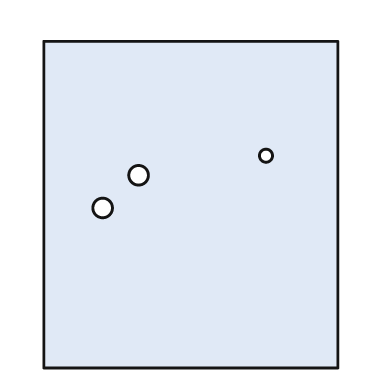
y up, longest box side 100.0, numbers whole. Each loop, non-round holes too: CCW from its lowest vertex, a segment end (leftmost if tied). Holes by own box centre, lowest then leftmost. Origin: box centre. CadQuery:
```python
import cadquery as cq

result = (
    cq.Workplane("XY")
    .moveTo(-45.0, -50.0)
    .lineTo(45.0, -50.0)
    .lineTo(45.0, 50.0)
    .lineTo(-45.0, 50.0)
    .close()
    .moveTo(-27.0, -1.0)
    .circle(3.0)
    .moveTo(-16.0, 9.0)
    .circle(3.0)
    .moveTo(23.0, 15.0)
    .circle(2.0)
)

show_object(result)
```